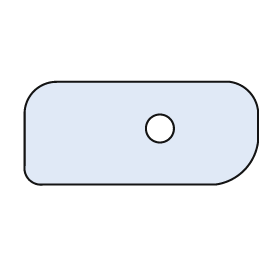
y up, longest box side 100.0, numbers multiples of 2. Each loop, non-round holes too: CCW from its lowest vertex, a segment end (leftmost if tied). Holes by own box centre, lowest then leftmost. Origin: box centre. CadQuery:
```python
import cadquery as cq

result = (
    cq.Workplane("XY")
    .moveTo(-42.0, -22.0)
    .lineTo(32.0, -22.0)
    .threePointArc((44.0, -16.0), (50.0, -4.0))
    .lineTo(50.0, 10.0)
    .threePointArc((46.0, 18.0), (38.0, 22.0))
    .lineTo(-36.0, 22.0)
    .threePointArc((-46.0, 18.0), (-50.0, 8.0))
    .lineTo(-50.0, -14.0)
    .threePointArc((-48.0, -20.0), (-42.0, -22.0))
    .close()
    .moveTo(8.0, 2.0)
    .circle(6.0)
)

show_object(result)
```